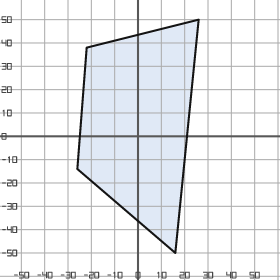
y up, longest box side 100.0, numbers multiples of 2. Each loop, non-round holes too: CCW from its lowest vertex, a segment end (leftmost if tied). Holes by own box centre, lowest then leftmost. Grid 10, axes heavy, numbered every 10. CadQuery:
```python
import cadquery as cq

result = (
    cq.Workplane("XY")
    .moveTo(16.0, -50.0)
    .lineTo(26.0, 50.0)
    .lineTo(-22.0, 38.0)
    .lineTo(-26.0, -14.0)
    .close()
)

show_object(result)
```